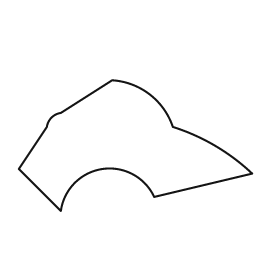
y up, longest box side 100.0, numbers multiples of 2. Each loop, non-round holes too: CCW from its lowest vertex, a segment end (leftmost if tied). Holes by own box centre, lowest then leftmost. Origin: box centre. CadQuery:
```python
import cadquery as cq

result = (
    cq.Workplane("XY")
    .moveTo(-32.0, -28.0)
    .threePointArc((-14.0, -10.0), (8.0, -22.0))
    .lineTo(50.0, -12.0)
    .threePointArc((34.0, 0.0), (16.0, 8.0))
    .threePointArc((6.0, 22.0), (-10.0, 28.0))
    .lineTo(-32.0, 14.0)
    .threePointArc((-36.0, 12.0), (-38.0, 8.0))
    .lineTo(-50.0, -10.0)
    .close()
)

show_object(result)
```